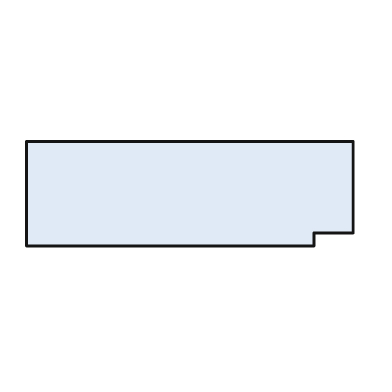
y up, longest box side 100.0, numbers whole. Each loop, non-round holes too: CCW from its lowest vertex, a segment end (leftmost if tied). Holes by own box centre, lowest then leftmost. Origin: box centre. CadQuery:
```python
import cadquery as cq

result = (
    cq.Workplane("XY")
    .moveTo(-50.0, -16.0)
    .lineTo(38.0, -16.0)
    .lineTo(38.0, -12.0)
    .lineTo(50.0, -12.0)
    .lineTo(50.0, 16.0)
    .lineTo(-50.0, 16.0)
    .close()
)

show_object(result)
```